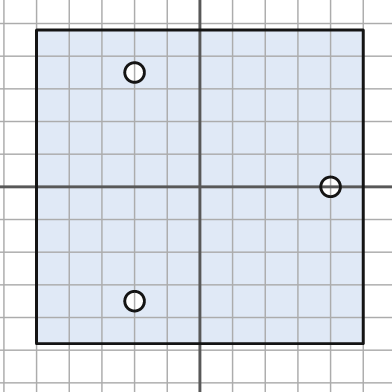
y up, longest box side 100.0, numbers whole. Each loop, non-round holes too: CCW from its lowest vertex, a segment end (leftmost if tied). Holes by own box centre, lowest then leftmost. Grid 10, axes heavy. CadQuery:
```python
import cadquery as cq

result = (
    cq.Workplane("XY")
    .moveTo(-50.0, -48.0)
    .lineTo(50.0, -48.0)
    .lineTo(50.0, 48.0)
    .lineTo(-50.0, 48.0)
    .close()
    .moveTo(-20.0, -35.0)
    .circle(3.0)
    .moveTo(40.0, 0.0)
    .circle(3.0)
    .moveTo(-20.0, 35.0)
    .circle(3.0)
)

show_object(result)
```